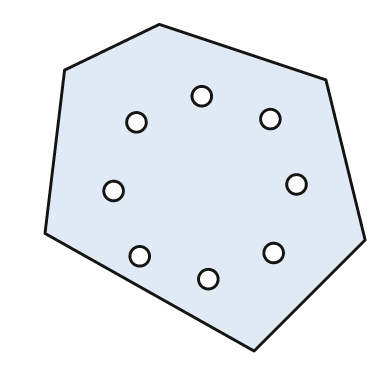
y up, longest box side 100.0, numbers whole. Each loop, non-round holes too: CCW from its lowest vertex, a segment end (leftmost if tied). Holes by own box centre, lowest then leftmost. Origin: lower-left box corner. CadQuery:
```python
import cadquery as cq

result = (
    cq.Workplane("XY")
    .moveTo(64.0, 0.0)
    .lineTo(98.0, 34.0)
    .lineTo(86.0, 83.0)
    .lineTo(35.0, 100.0)
    .lineTo(6.0, 86.0)
    .lineTo(0.0, 36.0)
    .close()
    .moveTo(50.0, 22.0)
    .circle(3.0)
    .moveTo(29.0, 29.0)
    .circle(3.0)
    .moveTo(70.0, 30.0)
    .circle(3.0)
    .moveTo(21.0, 49.0)
    .circle(3.0)
    .moveTo(77.0, 51.0)
    .circle(3.0)
    .moveTo(28.0, 70.0)
    .circle(3.0)
    .moveTo(69.0, 71.0)
    .circle(3.0)
    .moveTo(48.0, 78.0)
    .circle(3.0)
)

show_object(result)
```